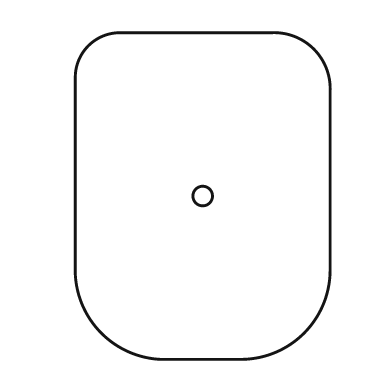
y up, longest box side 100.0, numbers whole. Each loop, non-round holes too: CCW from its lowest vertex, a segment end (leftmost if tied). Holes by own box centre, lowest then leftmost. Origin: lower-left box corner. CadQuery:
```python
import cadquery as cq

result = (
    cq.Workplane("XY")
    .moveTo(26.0, 0.0)
    .lineTo(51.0, 0.0)
    .threePointArc((70.0, 8.0), (78.0, 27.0))
    .lineTo(78.0, 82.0)
    .threePointArc((73.0, 95.0), (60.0, 100.0))
    .lineTo(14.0, 100.0)
    .threePointArc((4.0, 96.0), (0.0, 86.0))
    .lineTo(0.0, 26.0)
    .threePointArc((8.0, 8.0), (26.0, 0.0))
    .close()
    .moveTo(39.0, 50.0)
    .circle(3.0)
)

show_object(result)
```